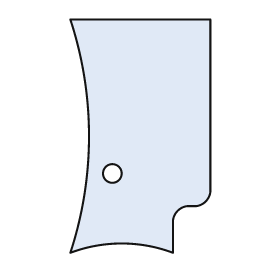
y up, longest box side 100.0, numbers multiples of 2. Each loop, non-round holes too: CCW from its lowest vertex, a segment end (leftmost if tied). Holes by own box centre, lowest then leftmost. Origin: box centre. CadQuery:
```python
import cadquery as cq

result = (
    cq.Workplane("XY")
    .moveTo(-30.0, -50.0)
    .threePointArc((-8.0, -46.0), (14.0, -50.0))
    .lineTo(14.0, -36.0)
    .threePointArc((16.0, -32.0), (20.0, -30.0))
    .lineTo(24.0, -30.0)
    .threePointArc((28.0, -28.0), (30.0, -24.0))
    .lineTo(30.0, 50.0)
    .lineTo(-30.0, 50.0)
    .threePointArc((-22.0, 0.0), (-30.0, -50.0))
    .close()
    .moveTo(-12.0, -16.0)
    .circle(4.0)
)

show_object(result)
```